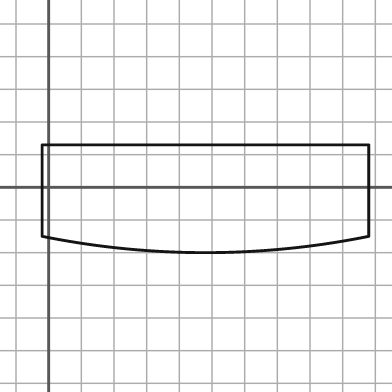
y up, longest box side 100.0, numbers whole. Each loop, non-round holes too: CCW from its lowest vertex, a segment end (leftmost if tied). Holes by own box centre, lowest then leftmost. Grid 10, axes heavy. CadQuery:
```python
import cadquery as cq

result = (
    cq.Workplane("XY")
    .moveTo(-2.0, -15.0)
    .threePointArc((48.0, -20.0), (98.0, -15.0))
    .lineTo(98.0, 13.0)
    .lineTo(-2.0, 13.0)
    .close()
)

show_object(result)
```